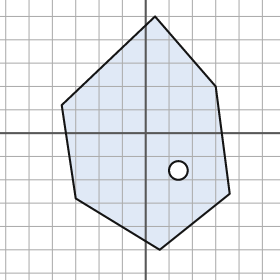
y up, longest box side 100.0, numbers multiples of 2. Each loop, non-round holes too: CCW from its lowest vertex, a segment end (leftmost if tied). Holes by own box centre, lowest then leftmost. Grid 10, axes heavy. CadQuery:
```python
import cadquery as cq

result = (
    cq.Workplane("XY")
    .moveTo(6.0, -50.0)
    .lineTo(36.0, -26.0)
    .lineTo(30.0, 20.0)
    .lineTo(4.0, 50.0)
    .lineTo(-36.0, 12.0)
    .lineTo(-30.0, -28.0)
    .close()
    .moveTo(14.0, -16.0)
    .circle(4.0)
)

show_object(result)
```